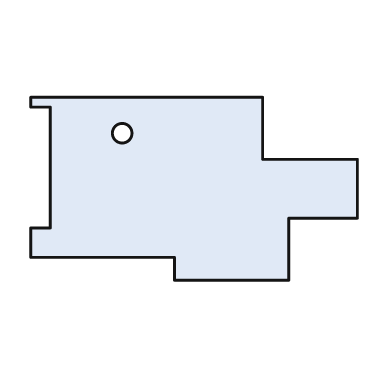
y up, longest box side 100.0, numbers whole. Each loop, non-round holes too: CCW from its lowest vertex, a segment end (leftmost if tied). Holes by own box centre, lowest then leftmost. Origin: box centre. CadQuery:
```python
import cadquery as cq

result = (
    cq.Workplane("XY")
    .moveTo(-6.0, -28.0)
    .lineTo(29.0, -28.0)
    .lineTo(29.0, -9.0)
    .lineTo(50.0, -9.0)
    .lineTo(50.0, 9.0)
    .lineTo(21.0, 9.0)
    .lineTo(21.0, 28.0)
    .lineTo(-50.0, 28.0)
    .lineTo(-50.0, 25.0)
    .lineTo(-44.0, 25.0)
    .lineTo(-44.0, -12.0)
    .lineTo(-50.0, -12.0)
    .lineTo(-50.0, -21.0)
    .lineTo(-6.0, -21.0)
    .close()
    .moveTo(-22.0, 17.0)
    .circle(3.0)
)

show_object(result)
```